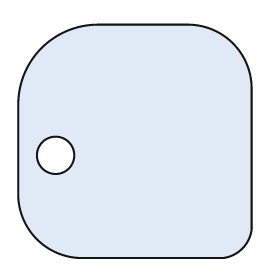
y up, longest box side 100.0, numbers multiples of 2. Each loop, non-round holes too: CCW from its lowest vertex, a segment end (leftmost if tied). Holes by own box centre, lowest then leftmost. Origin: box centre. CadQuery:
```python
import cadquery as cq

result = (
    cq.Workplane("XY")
    .moveTo(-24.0, -50.0)
    .lineTo(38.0, -50.0)
    .threePointArc((46.0, -46.0), (50.0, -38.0))
    .lineTo(50.0, 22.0)
    .threePointArc((42.0, 42.0), (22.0, 50.0))
    .lineTo(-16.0, 50.0)
    .threePointArc((-40.0, 40.0), (-50.0, 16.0))
    .lineTo(-50.0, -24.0)
    .threePointArc((-42.0, -42.0), (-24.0, -50.0))
    .close()
    .moveTo(-34.0, -6.0)
    .circle(8.0)
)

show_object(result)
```